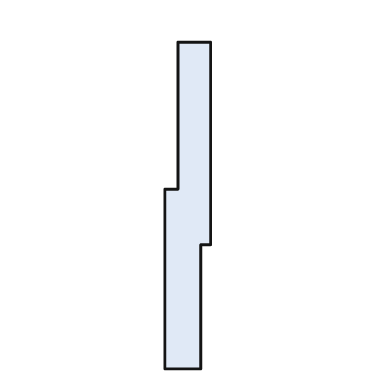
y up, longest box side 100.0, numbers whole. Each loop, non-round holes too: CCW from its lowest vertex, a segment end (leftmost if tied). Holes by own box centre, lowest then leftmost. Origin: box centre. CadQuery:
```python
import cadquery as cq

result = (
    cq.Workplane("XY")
    .moveTo(-7.0, -50.0)
    .lineTo(4.0, -50.0)
    .lineTo(4.0, -12.0)
    .lineTo(7.0, -12.0)
    .lineTo(7.0, 50.0)
    .lineTo(-3.0, 50.0)
    .lineTo(-3.0, 5.0)
    .lineTo(-7.0, 5.0)
    .close()
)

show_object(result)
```